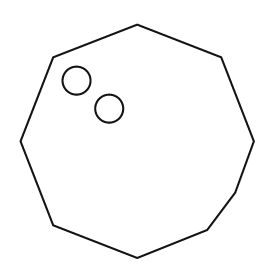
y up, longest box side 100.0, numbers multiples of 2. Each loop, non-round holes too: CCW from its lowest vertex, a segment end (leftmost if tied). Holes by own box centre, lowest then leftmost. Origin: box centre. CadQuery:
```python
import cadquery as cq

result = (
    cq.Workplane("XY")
    .moveTo(0.0, -50.0)
    .lineTo(30.0, -38.0)
    .lineTo(42.0, -22.0)
    .lineTo(50.0, 0.0)
    .lineTo(36.0, 36.0)
    .lineTo(0.0, 50.0)
    .lineTo(-36.0, 36.0)
    .lineTo(-50.0, 0.0)
    .lineTo(-36.0, -36.0)
    .close()
    .moveTo(-12.0, 14.0)
    .circle(6.0)
    .moveTo(-26.0, 26.0)
    .circle(6.0)
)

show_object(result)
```